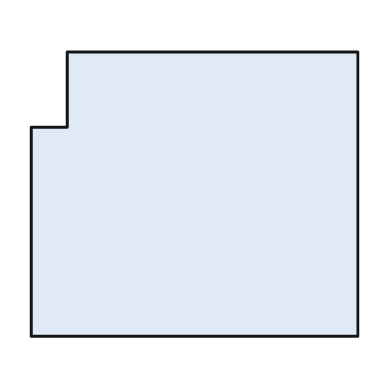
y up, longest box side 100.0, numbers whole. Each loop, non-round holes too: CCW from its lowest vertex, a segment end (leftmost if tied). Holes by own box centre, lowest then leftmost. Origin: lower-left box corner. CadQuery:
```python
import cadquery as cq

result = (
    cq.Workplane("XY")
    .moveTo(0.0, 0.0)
    .lineTo(100.0, 0.0)
    .lineTo(100.0, 87.0)
    .lineTo(11.0, 87.0)
    .lineTo(11.0, 64.0)
    .lineTo(0.0, 64.0)
    .close()
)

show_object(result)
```